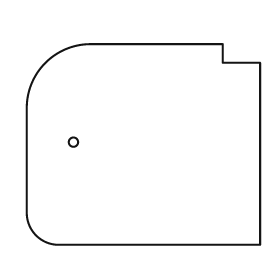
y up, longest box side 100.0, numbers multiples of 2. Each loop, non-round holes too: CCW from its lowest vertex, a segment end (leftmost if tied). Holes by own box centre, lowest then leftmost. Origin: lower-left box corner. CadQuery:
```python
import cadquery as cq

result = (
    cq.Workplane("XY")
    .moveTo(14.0, 0.0)
    .lineTo(100.0, 0.0)
    .lineTo(100.0, 78.0)
    .lineTo(84.0, 78.0)
    .lineTo(84.0, 86.0)
    .lineTo(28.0, 86.0)
    .threePointArc((8.0, 78.0), (0.0, 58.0))
    .lineTo(0.0, 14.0)
    .threePointArc((4.0, 4.0), (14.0, 0.0))
    .close()
    .moveTo(20.0, 44.0)
    .circle(2.0)
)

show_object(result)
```